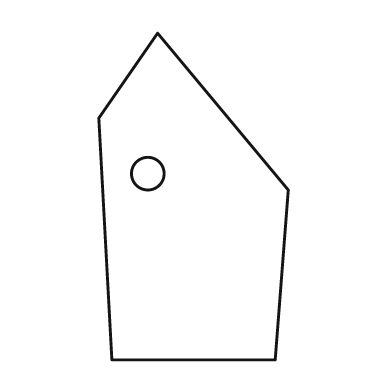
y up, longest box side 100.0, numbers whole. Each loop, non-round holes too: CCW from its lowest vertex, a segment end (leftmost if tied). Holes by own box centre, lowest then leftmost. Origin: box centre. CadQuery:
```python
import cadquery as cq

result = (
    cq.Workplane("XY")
    .moveTo(-25.0, -50.0)
    .lineTo(25.0, -50.0)
    .lineTo(29.0, 2.0)
    .lineTo(-11.0, 50.0)
    .lineTo(-29.0, 24.0)
    .close()
    .moveTo(-14.0, 7.0)
    .circle(5.0)
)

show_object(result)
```